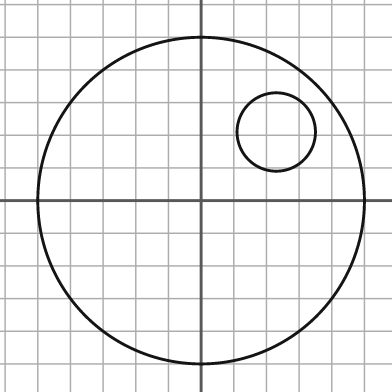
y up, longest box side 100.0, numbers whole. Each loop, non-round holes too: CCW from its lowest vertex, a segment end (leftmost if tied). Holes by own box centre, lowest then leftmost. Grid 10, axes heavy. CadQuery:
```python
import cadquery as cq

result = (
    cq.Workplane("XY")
    .moveTo(0.0, 0.0)
    .circle(50.0)
    .moveTo(23.0, 21.0)
    .circle(12.0)
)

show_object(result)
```